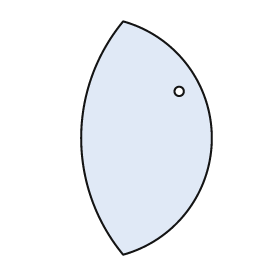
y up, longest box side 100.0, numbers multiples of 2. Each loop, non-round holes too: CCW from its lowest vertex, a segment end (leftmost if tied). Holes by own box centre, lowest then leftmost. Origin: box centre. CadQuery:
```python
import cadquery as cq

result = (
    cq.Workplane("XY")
    .moveTo(-10.0, -50.0)
    .threePointArc((28.0, 0.0), (-10.0, 50.0))
    .threePointArc((-28.0, 0.0), (-10.0, -50.0))
    .close()
    .moveTo(14.0, 20.0)
    .circle(2.0)
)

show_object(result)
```